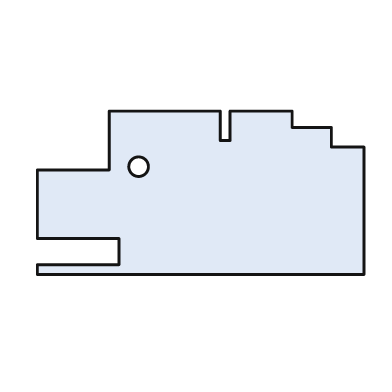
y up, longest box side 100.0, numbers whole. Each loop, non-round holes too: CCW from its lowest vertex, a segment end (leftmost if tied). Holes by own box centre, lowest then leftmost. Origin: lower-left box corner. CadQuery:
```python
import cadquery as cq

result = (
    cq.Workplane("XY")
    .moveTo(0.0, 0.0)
    .lineTo(100.0, 0.0)
    .lineTo(100.0, 39.0)
    .lineTo(90.0, 39.0)
    .lineTo(90.0, 45.0)
    .lineTo(78.0, 45.0)
    .lineTo(78.0, 50.0)
    .lineTo(59.0, 50.0)
    .lineTo(59.0, 41.0)
    .lineTo(56.0, 41.0)
    .lineTo(56.0, 50.0)
    .lineTo(22.0, 50.0)
    .lineTo(22.0, 32.0)
    .lineTo(0.0, 32.0)
    .lineTo(0.0, 11.0)
    .lineTo(25.0, 11.0)
    .lineTo(25.0, 3.0)
    .lineTo(0.0, 3.0)
    .close()
    .moveTo(31.0, 33.0)
    .circle(3.0)
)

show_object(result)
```